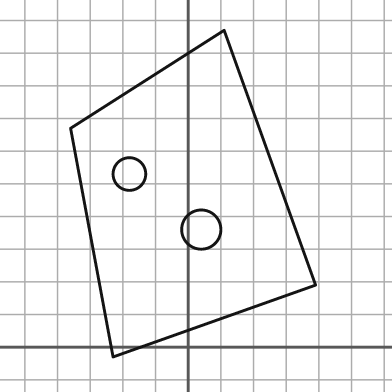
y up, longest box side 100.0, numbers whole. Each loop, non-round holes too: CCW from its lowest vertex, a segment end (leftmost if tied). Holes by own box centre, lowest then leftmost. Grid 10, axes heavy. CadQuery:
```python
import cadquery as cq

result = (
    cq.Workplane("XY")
    .moveTo(-23.0, -3.0)
    .lineTo(39.0, 19.0)
    .lineTo(11.0, 97.0)
    .lineTo(-36.0, 67.0)
    .close()
    .moveTo(4.0, 36.0)
    .circle(6.0)
    .moveTo(-18.0, 53.0)
    .circle(5.0)
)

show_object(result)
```